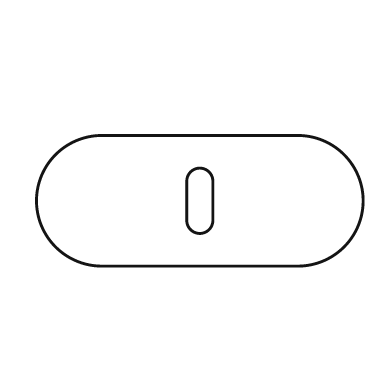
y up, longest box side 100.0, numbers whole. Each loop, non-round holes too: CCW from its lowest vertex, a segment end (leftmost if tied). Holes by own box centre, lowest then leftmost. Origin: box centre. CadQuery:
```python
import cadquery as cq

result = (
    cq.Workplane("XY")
    .moveTo(-30.0, -20.0)
    .lineTo(30.0, -20.0)
    .threePointArc((50.0, 0.0), (30.0, 20.0))
    .lineTo(-30.0, 20.0)
    .threePointArc((-50.0, 0.0), (-30.0, -20.0))
    .close()
    .moveTo(-4.0, -6.0)
    .threePointArc((0.0, -10.0), (4.0, -6.0))
    .lineTo(4.0, 6.0)
    .threePointArc((0.0, 10.0), (-4.0, 6.0))
    .close()
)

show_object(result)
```